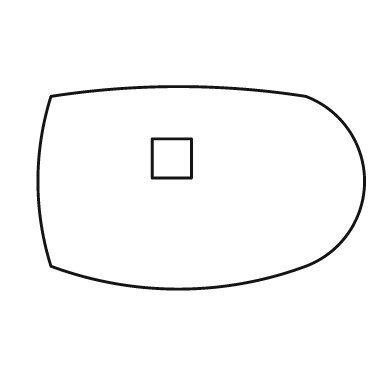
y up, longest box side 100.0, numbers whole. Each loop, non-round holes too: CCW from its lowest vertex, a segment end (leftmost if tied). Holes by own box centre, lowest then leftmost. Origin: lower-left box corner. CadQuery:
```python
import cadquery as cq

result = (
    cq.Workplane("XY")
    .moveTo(4.0, 7.0)
    .threePointArc((43.0, 0.0), (82.0, 7.0))
    .threePointArc((100.0, 33.0), (82.0, 59.0))
    .threePointArc((43.0, 62.0), (4.0, 59.0))
    .threePointArc((0.0, 33.0), (4.0, 7.0))
    .close()
    .moveTo(35.0, 34.0)
    .lineTo(47.0, 34.0)
    .lineTo(47.0, 46.0)
    .lineTo(35.0, 46.0)
    .close()
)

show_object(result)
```